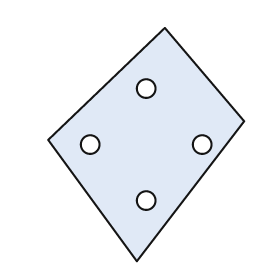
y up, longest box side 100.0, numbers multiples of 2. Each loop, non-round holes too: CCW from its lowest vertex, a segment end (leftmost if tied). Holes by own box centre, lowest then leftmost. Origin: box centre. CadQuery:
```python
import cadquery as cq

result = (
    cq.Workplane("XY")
    .moveTo(-4.0, -50.0)
    .lineTo(42.0, 10.0)
    .lineTo(8.0, 50.0)
    .lineTo(-42.0, 2.0)
    .close()
    .moveTo(0.0, -24.0)
    .circle(4.0)
    .moveTo(-24.0, 0.0)
    .circle(4.0)
    .moveTo(24.0, 0.0)
    .circle(4.0)
    .moveTo(0.0, 24.0)
    .circle(4.0)
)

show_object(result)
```